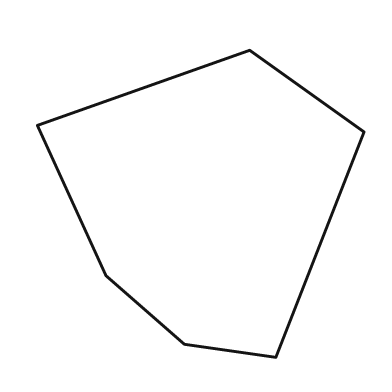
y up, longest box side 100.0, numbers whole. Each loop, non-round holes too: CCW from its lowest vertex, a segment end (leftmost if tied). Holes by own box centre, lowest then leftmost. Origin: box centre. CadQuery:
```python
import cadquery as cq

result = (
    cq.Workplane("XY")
    .moveTo(23.0, -47.0)
    .lineTo(50.0, 22.0)
    .lineTo(15.0, 47.0)
    .lineTo(-50.0, 24.0)
    .lineTo(-29.0, -22.0)
    .lineTo(-5.0, -43.0)
    .close()
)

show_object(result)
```